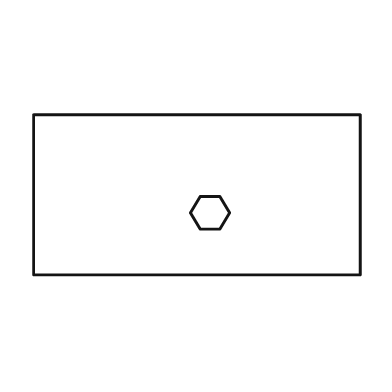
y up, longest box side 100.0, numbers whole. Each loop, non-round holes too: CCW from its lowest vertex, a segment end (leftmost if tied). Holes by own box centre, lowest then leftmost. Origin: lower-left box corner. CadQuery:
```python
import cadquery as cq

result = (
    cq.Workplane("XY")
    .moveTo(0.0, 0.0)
    .lineTo(100.0, 0.0)
    .lineTo(100.0, 49.0)
    .lineTo(0.0, 49.0)
    .close()
    .moveTo(51.0, 14.0)
    .lineTo(57.0, 14.0)
    .lineTo(60.0, 19.0)
    .lineTo(57.0, 24.0)
    .lineTo(51.0, 24.0)
    .lineTo(48.0, 19.0)
    .close()
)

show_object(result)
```